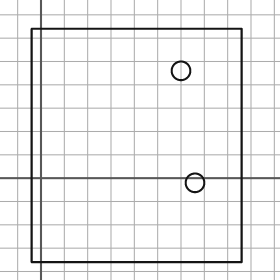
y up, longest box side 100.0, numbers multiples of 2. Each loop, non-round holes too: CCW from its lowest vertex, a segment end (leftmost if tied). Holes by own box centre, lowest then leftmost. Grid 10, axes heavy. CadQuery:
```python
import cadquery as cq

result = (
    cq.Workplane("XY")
    .moveTo(-4.0, -36.0)
    .lineTo(86.0, -36.0)
    .lineTo(86.0, 64.0)
    .lineTo(-4.0, 64.0)
    .close()
    .moveTo(66.0, -2.0)
    .circle(4.0)
    .moveTo(60.0, 46.0)
    .circle(4.0)
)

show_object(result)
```